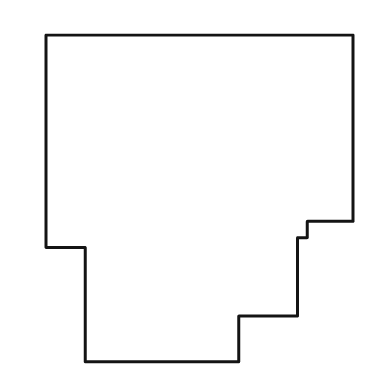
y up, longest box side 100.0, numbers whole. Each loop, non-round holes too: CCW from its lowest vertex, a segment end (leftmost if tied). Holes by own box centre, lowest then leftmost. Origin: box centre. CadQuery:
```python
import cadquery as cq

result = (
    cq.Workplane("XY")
    .moveTo(-35.0, -50.0)
    .lineTo(12.0, -50.0)
    .lineTo(12.0, -36.0)
    .lineTo(30.0, -36.0)
    .lineTo(30.0, -12.0)
    .lineTo(33.0, -12.0)
    .lineTo(33.0, -7.0)
    .lineTo(47.0, -7.0)
    .lineTo(47.0, 50.0)
    .lineTo(-47.0, 50.0)
    .lineTo(-47.0, -15.0)
    .lineTo(-35.0, -15.0)
    .close()
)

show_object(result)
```